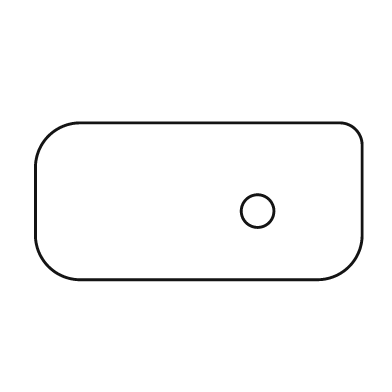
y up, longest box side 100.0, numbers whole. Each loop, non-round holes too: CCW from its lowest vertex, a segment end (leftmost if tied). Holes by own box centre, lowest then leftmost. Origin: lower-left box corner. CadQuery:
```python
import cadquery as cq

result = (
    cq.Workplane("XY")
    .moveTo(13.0, 0.0)
    .lineTo(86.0, 0.0)
    .threePointArc((96.0, 4.0), (100.0, 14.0))
    .lineTo(100.0, 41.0)
    .threePointArc((98.0, 46.0), (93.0, 48.0))
    .lineTo(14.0, 48.0)
    .threePointArc((4.0, 44.0), (0.0, 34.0))
    .lineTo(0.0, 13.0)
    .threePointArc((4.0, 4.0), (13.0, 0.0))
    .close()
    .moveTo(68.0, 21.0)
    .circle(5.0)
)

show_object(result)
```